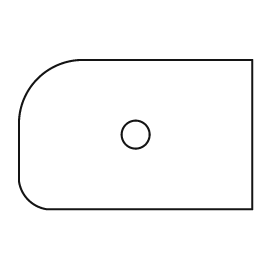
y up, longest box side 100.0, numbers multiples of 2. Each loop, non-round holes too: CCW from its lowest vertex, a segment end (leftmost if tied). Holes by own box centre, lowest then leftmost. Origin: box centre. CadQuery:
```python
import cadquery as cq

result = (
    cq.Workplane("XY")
    .moveTo(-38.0, -32.0)
    .lineTo(50.0, -32.0)
    .lineTo(50.0, 32.0)
    .lineTo(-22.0, 32.0)
    .threePointArc((-42.0, 24.0), (-50.0, 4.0))
    .lineTo(-50.0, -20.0)
    .threePointArc((-46.0, -28.0), (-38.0, -32.0))
    .close()
    .moveTo(0.0, 0.0)
    .circle(6.0)
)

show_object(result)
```